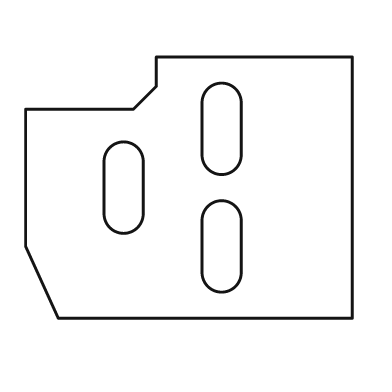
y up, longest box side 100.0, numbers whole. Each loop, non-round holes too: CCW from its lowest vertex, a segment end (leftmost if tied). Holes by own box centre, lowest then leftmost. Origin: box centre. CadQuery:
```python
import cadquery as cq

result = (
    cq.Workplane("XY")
    .moveTo(-40.0, -40.0)
    .lineTo(50.0, -40.0)
    .lineTo(50.0, 40.0)
    .lineTo(-10.0, 40.0)
    .lineTo(-10.0, 31.0)
    .lineTo(-17.0, 24.0)
    .lineTo(-50.0, 24.0)
    .lineTo(-50.0, -18.0)
    .close()
    .moveTo(4.0, -26.0)
    .threePointArc((10.0, -32.0), (16.0, -26.0))
    .lineTo(16.0, -10.0)
    .threePointArc((10.0, -4.0), (4.0, -10.0))
    .close()
    .moveTo(-26.0, -8.0)
    .threePointArc((-20.0, -14.0), (-14.0, -8.0))
    .lineTo(-14.0, 8.0)
    .threePointArc((-20.0, 14.0), (-26.0, 8.0))
    .close()
    .moveTo(4.0, 10.0)
    .threePointArc((10.0, 4.0), (16.0, 10.0))
    .lineTo(16.0, 26.0)
    .threePointArc((10.0, 32.0), (4.0, 26.0))
    .close()
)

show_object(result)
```